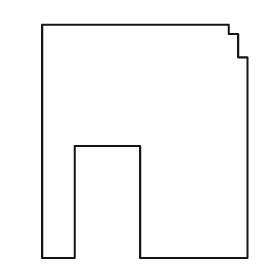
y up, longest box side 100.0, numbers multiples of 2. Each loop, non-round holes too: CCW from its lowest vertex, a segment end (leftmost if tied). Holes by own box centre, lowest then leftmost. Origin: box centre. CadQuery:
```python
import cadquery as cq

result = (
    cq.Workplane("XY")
    .moveTo(-44.0, -50.0)
    .lineTo(-30.0, -50.0)
    .lineTo(-30.0, -2.0)
    .lineTo(-2.0, -2.0)
    .lineTo(-2.0, -50.0)
    .lineTo(44.0, -50.0)
    .lineTo(44.0, 36.0)
    .lineTo(40.0, 36.0)
    .lineTo(40.0, 46.0)
    .lineTo(36.0, 46.0)
    .lineTo(36.0, 50.0)
    .lineTo(-44.0, 50.0)
    .close()
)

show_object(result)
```